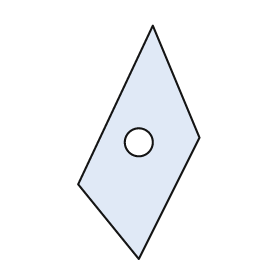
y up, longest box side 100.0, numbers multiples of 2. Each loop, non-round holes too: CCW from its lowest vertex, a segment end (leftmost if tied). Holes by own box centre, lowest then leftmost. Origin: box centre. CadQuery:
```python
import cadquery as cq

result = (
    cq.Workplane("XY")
    .moveTo(0.0, -50.0)
    .lineTo(26.0, 2.0)
    .lineTo(6.0, 50.0)
    .lineTo(-26.0, -18.0)
    .close()
    .moveTo(0.0, 0.0)
    .circle(6.0)
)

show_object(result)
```